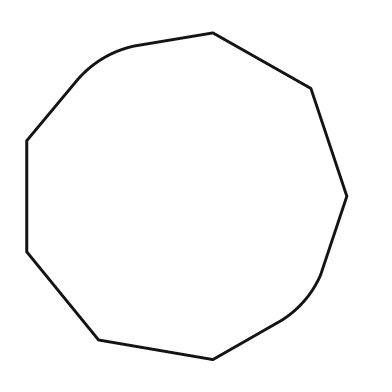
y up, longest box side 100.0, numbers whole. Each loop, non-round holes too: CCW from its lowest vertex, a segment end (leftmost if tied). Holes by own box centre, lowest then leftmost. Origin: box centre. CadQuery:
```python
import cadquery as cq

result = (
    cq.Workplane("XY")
    .moveTo(8.0, -50.0)
    .lineTo(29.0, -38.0)
    .threePointArc((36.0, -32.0), (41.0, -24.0))
    .lineTo(49.0, 0.0)
    .lineTo(38.0, 33.0)
    .lineTo(8.0, 50.0)
    .lineTo(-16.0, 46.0)
    .threePointArc((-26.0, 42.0), (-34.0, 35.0))
    .lineTo(-49.0, 17.0)
    .lineTo(-49.0, -17.0)
    .lineTo(-27.0, -44.0)
    .close()
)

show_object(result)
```